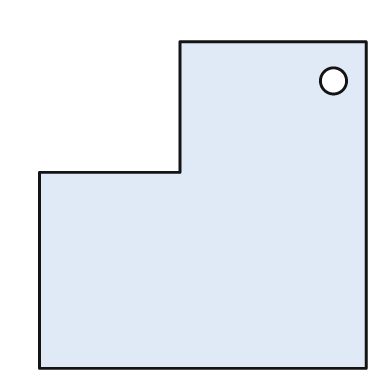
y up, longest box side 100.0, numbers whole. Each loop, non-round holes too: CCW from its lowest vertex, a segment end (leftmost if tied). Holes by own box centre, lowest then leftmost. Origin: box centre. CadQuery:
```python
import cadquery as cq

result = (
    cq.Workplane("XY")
    .moveTo(-50.0, -50.0)
    .lineTo(50.0, -50.0)
    .lineTo(50.0, 50.0)
    .lineTo(-7.0, 50.0)
    .lineTo(-7.0, 10.0)
    .lineTo(-50.0, 10.0)
    .close()
    .moveTo(40.0, 38.0)
    .circle(4.0)
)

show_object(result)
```